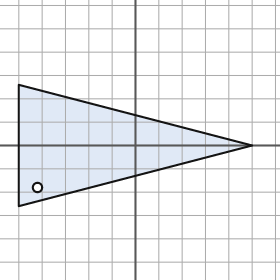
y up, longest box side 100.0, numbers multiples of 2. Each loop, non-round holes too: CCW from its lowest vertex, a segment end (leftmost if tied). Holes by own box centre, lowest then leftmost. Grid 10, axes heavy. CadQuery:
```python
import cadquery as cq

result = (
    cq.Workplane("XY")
    .moveTo(-50.0, -26.0)
    .lineTo(50.0, 0.0)
    .lineTo(-50.0, 26.0)
    .close()
    .moveTo(-42.0, -18.0)
    .circle(2.0)
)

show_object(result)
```